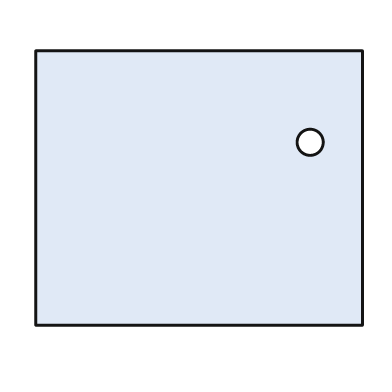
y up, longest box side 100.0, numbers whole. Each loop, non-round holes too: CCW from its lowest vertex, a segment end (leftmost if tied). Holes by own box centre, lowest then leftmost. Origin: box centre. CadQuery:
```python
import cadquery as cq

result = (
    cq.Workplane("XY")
    .moveTo(-50.0, -42.0)
    .lineTo(50.0, -42.0)
    .lineTo(50.0, 42.0)
    .lineTo(-50.0, 42.0)
    .close()
    .moveTo(34.0, 14.0)
    .circle(4.0)
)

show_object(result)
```